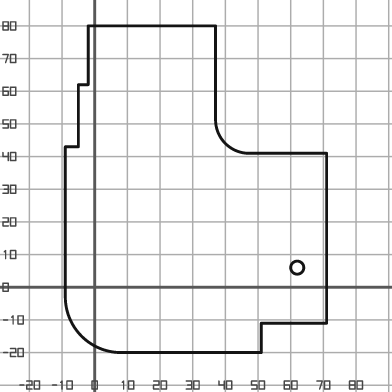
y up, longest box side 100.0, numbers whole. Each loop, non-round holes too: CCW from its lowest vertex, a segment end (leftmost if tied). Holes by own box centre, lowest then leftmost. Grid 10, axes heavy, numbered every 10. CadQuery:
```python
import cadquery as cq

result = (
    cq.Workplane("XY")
    .moveTo(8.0, -20.0)
    .lineTo(51.0, -20.0)
    .lineTo(51.0, -11.0)
    .lineTo(71.0, -11.0)
    .lineTo(71.0, 41.0)
    .lineTo(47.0, 41.0)
    .threePointArc((40.0, 44.0), (37.0, 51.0))
    .lineTo(37.0, 80.0)
    .lineTo(-2.0, 80.0)
    .lineTo(-2.0, 62.0)
    .lineTo(-5.0, 62.0)
    .lineTo(-5.0, 43.0)
    .lineTo(-9.0, 43.0)
    .lineTo(-9.0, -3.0)
    .threePointArc((-4.0, -15.0), (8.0, -20.0))
    .close()
    .moveTo(62.0, 6.0)
    .circle(2.0)
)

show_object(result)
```